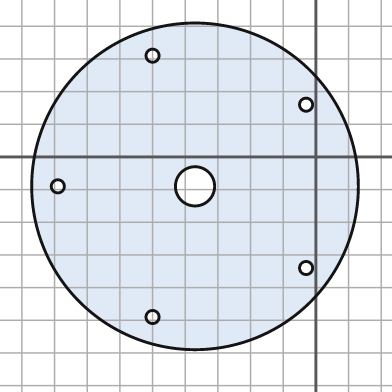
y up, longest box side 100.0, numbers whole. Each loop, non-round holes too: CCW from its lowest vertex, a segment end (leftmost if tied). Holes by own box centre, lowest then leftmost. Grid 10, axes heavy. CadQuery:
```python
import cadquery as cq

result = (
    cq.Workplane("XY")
    .moveTo(-37.0, -9.0)
    .circle(50.0)
    .moveTo(-50.0, -49.0)
    .circle(2.0)
    .moveTo(-3.0, -34.0)
    .circle(2.0)
    .moveTo(-79.0, -9.0)
    .circle(2.0)
    .moveTo(-37.0, -9.0)
    .circle(6.0)
    .moveTo(-3.0, 16.0)
    .circle(2.0)
    .moveTo(-50.0, 31.0)
    .circle(2.0)
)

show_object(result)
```